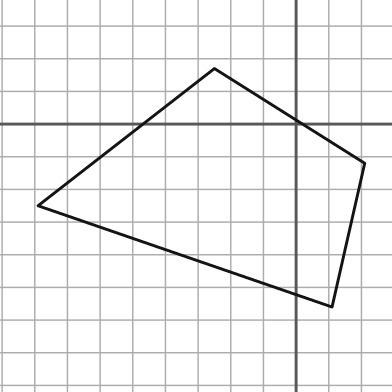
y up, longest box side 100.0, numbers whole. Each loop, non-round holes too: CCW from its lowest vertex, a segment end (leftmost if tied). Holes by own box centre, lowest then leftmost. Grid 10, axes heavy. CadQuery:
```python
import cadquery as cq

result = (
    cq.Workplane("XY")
    .moveTo(11.0, -56.0)
    .lineTo(21.0, -12.0)
    .lineTo(-25.0, 17.0)
    .lineTo(-79.0, -25.0)
    .close()
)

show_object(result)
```